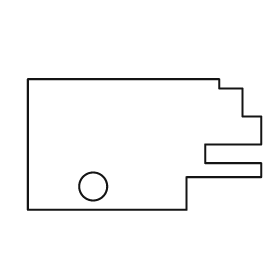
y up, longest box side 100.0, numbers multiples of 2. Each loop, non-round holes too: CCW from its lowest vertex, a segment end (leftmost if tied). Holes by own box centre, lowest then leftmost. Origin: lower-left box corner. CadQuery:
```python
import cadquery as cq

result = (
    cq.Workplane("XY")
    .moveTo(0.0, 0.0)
    .lineTo(68.0, 0.0)
    .lineTo(68.0, 14.0)
    .lineTo(100.0, 14.0)
    .lineTo(100.0, 20.0)
    .lineTo(76.0, 20.0)
    .lineTo(76.0, 28.0)
    .lineTo(100.0, 28.0)
    .lineTo(100.0, 40.0)
    .lineTo(92.0, 40.0)
    .lineTo(92.0, 52.0)
    .lineTo(82.0, 52.0)
    .lineTo(82.0, 56.0)
    .lineTo(0.0, 56.0)
    .close()
    .moveTo(28.0, 10.0)
    .circle(6.0)
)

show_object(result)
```